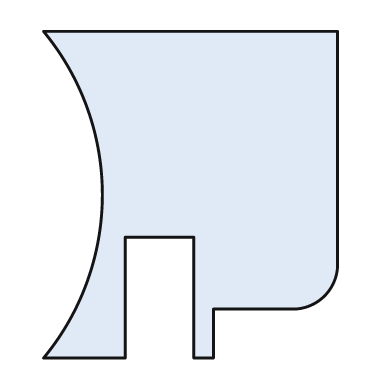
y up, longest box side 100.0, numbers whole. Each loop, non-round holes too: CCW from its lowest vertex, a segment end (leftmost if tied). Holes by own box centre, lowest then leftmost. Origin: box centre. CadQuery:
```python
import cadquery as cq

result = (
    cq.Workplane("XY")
    .moveTo(-45.0, -50.0)
    .lineTo(-20.0, -50.0)
    .lineTo(-20.0, -13.0)
    .lineTo(1.0, -13.0)
    .lineTo(1.0, -50.0)
    .lineTo(7.0, -50.0)
    .lineTo(7.0, -35.0)
    .lineTo(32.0, -35.0)
    .threePointArc((41.0, -31.0), (45.0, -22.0))
    .lineTo(45.0, 50.0)
    .lineTo(-45.0, 50.0)
    .threePointArc((-27.0, 0.0), (-45.0, -50.0))
    .close()
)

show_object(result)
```